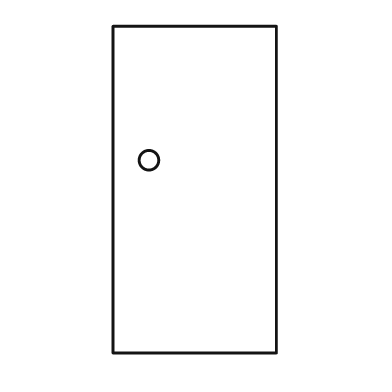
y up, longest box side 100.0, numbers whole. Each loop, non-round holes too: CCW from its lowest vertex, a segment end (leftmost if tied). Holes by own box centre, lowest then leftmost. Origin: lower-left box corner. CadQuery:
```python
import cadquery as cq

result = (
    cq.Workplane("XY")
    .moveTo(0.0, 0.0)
    .lineTo(50.0, 0.0)
    .lineTo(50.0, 100.0)
    .lineTo(0.0, 100.0)
    .close()
    .moveTo(11.0, 59.0)
    .circle(3.0)
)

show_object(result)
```